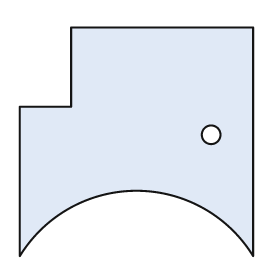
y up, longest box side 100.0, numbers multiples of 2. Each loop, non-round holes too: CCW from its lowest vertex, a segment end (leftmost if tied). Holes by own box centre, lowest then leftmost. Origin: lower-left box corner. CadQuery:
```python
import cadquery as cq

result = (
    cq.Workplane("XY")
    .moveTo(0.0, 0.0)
    .threePointArc((50.0, 28.0), (100.0, 0.0))
    .lineTo(100.0, 98.0)
    .lineTo(22.0, 98.0)
    .lineTo(22.0, 64.0)
    .lineTo(0.0, 64.0)
    .close()
    .moveTo(82.0, 52.0)
    .circle(4.0)
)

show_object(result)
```